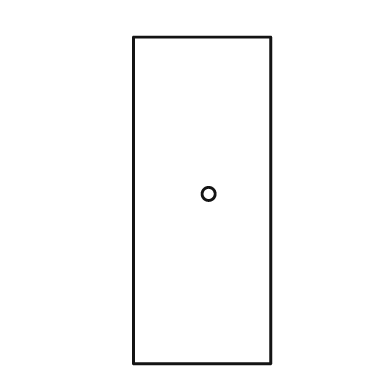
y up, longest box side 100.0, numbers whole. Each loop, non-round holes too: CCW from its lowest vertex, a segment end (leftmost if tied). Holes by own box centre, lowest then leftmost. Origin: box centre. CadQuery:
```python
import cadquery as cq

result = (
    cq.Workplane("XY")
    .moveTo(-21.0, -50.0)
    .lineTo(21.0, -50.0)
    .lineTo(21.0, 50.0)
    .lineTo(-21.0, 50.0)
    .close()
    .moveTo(2.0, 2.0)
    .circle(2.0)
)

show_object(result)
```